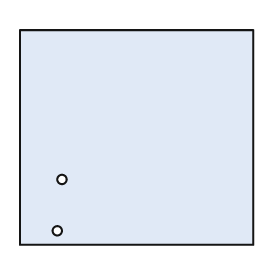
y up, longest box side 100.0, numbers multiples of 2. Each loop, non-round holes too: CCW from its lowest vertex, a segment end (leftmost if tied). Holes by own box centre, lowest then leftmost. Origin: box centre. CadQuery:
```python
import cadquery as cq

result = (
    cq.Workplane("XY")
    .moveTo(-50.0, -46.0)
    .lineTo(50.0, -46.0)
    .lineTo(50.0, 46.0)
    .lineTo(-50.0, 46.0)
    .close()
    .moveTo(-34.0, -40.0)
    .circle(2.0)
    .moveTo(-32.0, -18.0)
    .circle(2.0)
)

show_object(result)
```